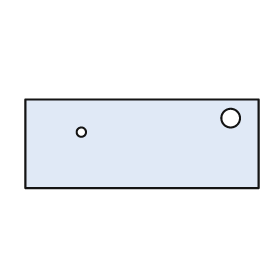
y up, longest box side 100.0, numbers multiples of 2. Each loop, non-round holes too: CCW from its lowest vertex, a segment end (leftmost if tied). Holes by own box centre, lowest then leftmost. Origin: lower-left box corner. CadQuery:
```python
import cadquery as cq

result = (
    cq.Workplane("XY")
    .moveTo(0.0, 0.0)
    .lineTo(100.0, 0.0)
    .lineTo(100.0, 38.0)
    .lineTo(0.0, 38.0)
    .close()
    .moveTo(24.0, 24.0)
    .circle(2.0)
    .moveTo(88.0, 30.0)
    .circle(4.0)
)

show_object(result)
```